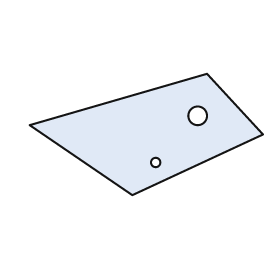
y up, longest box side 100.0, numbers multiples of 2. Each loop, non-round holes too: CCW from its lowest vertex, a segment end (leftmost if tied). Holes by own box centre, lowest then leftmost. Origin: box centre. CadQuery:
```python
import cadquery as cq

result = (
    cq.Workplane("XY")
    .moveTo(-6.0, -26.0)
    .lineTo(50.0, 0.0)
    .lineTo(26.0, 26.0)
    .lineTo(-50.0, 4.0)
    .close()
    .moveTo(4.0, -12.0)
    .circle(2.0)
    .moveTo(22.0, 8.0)
    .circle(4.0)
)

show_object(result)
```